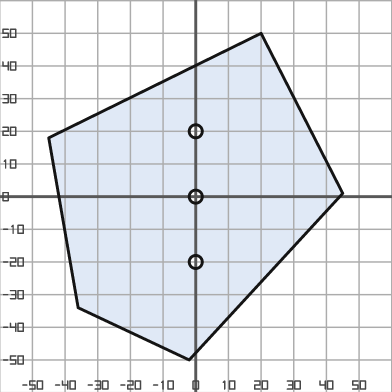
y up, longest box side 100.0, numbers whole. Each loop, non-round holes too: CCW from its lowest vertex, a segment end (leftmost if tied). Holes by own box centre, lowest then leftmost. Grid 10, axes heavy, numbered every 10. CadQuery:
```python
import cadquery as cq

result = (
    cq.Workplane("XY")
    .moveTo(-2.0, -50.0)
    .lineTo(45.0, 1.0)
    .lineTo(20.0, 50.0)
    .lineTo(-45.0, 18.0)
    .lineTo(-36.0, -34.0)
    .close()
    .moveTo(0.0, -20.0)
    .circle(2.0)
    .moveTo(0.0, 0.0)
    .circle(2.0)
    .moveTo(0.0, 20.0)
    .circle(2.0)
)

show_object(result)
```